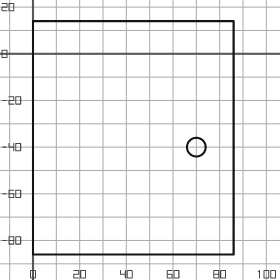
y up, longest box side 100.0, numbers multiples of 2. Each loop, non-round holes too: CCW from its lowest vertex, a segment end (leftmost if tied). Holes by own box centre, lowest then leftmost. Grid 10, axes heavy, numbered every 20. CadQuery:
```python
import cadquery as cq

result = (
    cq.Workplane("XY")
    .moveTo(0.0, -86.0)
    .lineTo(86.0, -86.0)
    .lineTo(86.0, 14.0)
    .lineTo(0.0, 14.0)
    .close()
    .moveTo(70.0, -40.0)
    .circle(4.0)
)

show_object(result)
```